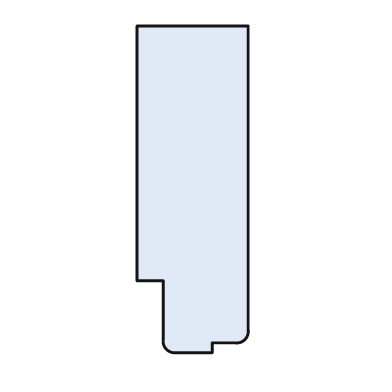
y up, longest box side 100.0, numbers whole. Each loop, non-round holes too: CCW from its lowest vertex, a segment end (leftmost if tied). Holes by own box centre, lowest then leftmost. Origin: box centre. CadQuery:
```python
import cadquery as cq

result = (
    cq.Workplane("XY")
    .moveTo(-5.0, -50.0)
    .lineTo(6.0, -50.0)
    .lineTo(6.0, -47.0)
    .lineTo(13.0, -47.0)
    .threePointArc((16.0, -46.0), (17.0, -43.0))
    .lineTo(17.0, 50.0)
    .lineTo(-17.0, 50.0)
    .lineTo(-17.0, -28.0)
    .lineTo(-9.0, -28.0)
    .lineTo(-9.0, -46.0)
    .threePointArc((-8.0, -49.0), (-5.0, -50.0))
    .close()
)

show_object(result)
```